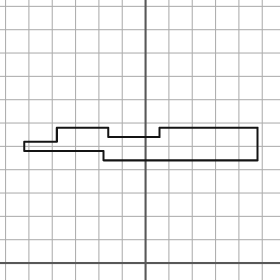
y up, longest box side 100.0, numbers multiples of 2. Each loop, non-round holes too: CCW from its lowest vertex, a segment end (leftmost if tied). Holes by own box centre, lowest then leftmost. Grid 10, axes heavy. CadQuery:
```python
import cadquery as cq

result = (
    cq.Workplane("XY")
    .moveTo(-18.0, 44.0)
    .lineTo(48.0, 44.0)
    .lineTo(48.0, 58.0)
    .lineTo(6.0, 58.0)
    .lineTo(6.0, 54.0)
    .lineTo(-16.0, 54.0)
    .lineTo(-16.0, 58.0)
    .lineTo(-38.0, 58.0)
    .lineTo(-38.0, 52.0)
    .lineTo(-52.0, 52.0)
    .lineTo(-52.0, 48.0)
    .lineTo(-18.0, 48.0)
    .close()
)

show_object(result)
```